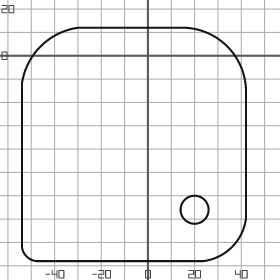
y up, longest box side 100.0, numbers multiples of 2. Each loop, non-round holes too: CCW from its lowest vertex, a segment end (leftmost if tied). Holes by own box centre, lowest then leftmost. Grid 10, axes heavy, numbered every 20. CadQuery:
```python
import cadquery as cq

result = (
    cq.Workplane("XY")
    .moveTo(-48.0, -88.0)
    .lineTo(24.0, -88.0)
    .threePointArc((36.0, -82.0), (42.0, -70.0))
    .lineTo(42.0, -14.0)
    .threePointArc((34.0, 4.0), (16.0, 12.0))
    .lineTo(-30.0, 12.0)
    .threePointArc((-46.0, 4.0), (-54.0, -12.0))
    .lineTo(-54.0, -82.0)
    .threePointArc((-52.0, -86.0), (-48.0, -88.0))
    .close()
    .moveTo(20.0, -66.0)
    .circle(6.0)
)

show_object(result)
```